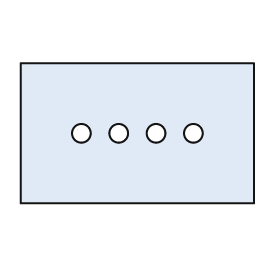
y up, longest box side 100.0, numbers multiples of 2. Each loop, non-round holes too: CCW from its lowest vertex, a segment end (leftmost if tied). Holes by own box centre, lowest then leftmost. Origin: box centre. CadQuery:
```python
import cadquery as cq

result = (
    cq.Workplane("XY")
    .moveTo(-50.0, -30.0)
    .lineTo(50.0, -30.0)
    .lineTo(50.0, 30.0)
    .lineTo(-50.0, 30.0)
    .close()
    .moveTo(-24.0, 0.0)
    .circle(4.0)
    .moveTo(-8.0, 0.0)
    .circle(4.0)
    .moveTo(8.0, 0.0)
    .circle(4.0)
    .moveTo(24.0, 0.0)
    .circle(4.0)
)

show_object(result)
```